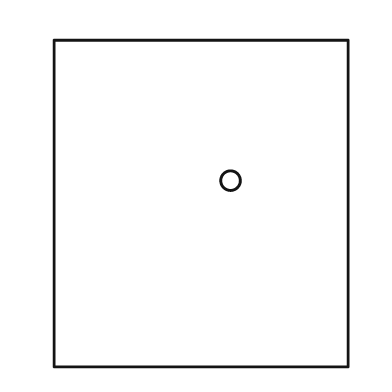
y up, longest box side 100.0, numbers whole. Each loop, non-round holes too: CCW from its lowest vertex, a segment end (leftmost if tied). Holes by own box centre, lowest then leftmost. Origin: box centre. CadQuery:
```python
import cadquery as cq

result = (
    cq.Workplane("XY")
    .moveTo(-45.0, -50.0)
    .lineTo(45.0, -50.0)
    .lineTo(45.0, 50.0)
    .lineTo(-45.0, 50.0)
    .close()
    .moveTo(9.0, 7.0)
    .circle(3.0)
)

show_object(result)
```